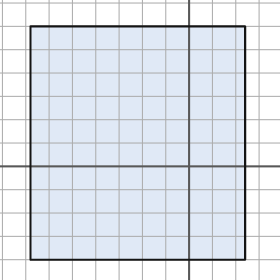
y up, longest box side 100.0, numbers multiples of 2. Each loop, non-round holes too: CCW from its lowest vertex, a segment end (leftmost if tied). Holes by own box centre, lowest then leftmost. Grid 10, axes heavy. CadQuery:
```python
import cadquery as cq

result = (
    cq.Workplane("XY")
    .moveTo(-68.0, -40.0)
    .lineTo(24.0, -40.0)
    .lineTo(24.0, 60.0)
    .lineTo(-68.0, 60.0)
    .close()
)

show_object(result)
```